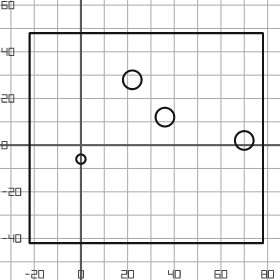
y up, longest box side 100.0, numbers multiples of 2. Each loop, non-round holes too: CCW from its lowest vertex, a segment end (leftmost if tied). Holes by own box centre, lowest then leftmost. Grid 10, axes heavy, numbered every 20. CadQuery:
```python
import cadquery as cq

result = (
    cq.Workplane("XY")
    .moveTo(-22.0, -42.0)
    .lineTo(78.0, -42.0)
    .lineTo(78.0, 48.0)
    .lineTo(-22.0, 48.0)
    .close()
    .moveTo(0.0, -6.0)
    .circle(2.0)
    .moveTo(70.0, 2.0)
    .circle(4.0)
    .moveTo(36.0, 12.0)
    .circle(4.0)
    .moveTo(22.0, 28.0)
    .circle(4.0)
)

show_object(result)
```